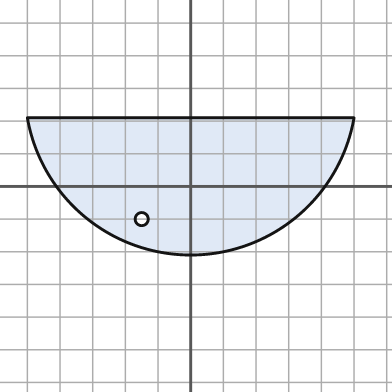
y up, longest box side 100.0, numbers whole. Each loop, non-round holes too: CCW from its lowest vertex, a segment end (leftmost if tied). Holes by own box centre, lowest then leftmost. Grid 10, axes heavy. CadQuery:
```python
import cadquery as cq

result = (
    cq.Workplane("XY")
    .moveTo(-50.0, 21.0)
    .threePointArc((0.0, -21.0), (50.0, 21.0))
    .close()
    .moveTo(-15.0, -10.0)
    .circle(2.0)
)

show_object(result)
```